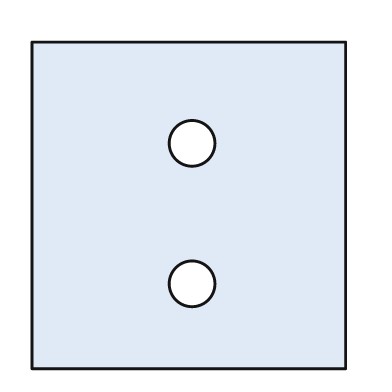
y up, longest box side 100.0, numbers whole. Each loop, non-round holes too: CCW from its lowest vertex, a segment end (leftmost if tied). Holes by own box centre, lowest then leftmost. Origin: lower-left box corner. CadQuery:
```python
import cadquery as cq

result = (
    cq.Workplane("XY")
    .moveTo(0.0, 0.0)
    .lineTo(96.0, 0.0)
    .lineTo(96.0, 100.0)
    .lineTo(0.0, 100.0)
    .close()
    .moveTo(49.0, 26.0)
    .circle(7.0)
    .moveTo(49.0, 69.0)
    .circle(7.0)
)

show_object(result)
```